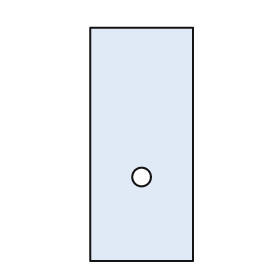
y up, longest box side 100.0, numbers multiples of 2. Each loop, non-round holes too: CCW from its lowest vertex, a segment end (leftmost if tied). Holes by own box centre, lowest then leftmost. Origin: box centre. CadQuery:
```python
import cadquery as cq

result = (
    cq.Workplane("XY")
    .moveTo(-22.0, -50.0)
    .lineTo(22.0, -50.0)
    .lineTo(22.0, 50.0)
    .lineTo(-22.0, 50.0)
    .close()
    .moveTo(0.0, -14.0)
    .circle(4.0)
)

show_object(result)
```